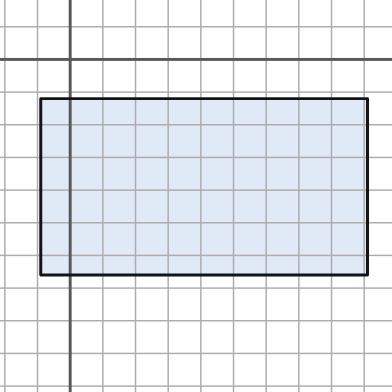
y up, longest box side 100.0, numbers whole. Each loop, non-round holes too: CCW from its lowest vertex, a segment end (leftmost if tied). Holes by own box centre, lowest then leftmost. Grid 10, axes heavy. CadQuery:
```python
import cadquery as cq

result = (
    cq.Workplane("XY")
    .moveTo(-9.0, -66.0)
    .lineTo(91.0, -66.0)
    .lineTo(91.0, -12.0)
    .lineTo(-9.0, -12.0)
    .close()
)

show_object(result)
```